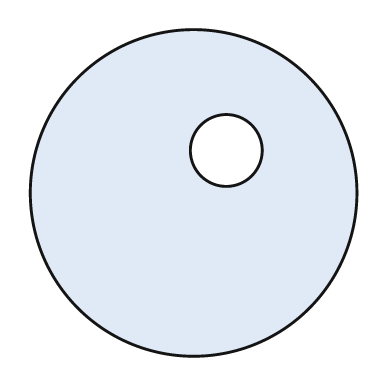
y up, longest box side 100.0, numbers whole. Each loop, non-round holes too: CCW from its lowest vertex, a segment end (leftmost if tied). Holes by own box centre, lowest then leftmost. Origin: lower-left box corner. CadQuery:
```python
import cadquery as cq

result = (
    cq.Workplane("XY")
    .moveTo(50.0, 50.0)
    .circle(50.0)
    .moveTo(60.0, 63.0)
    .circle(11.0)
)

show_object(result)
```